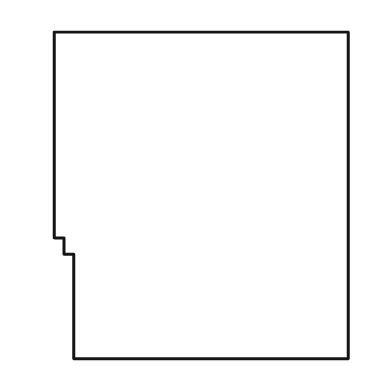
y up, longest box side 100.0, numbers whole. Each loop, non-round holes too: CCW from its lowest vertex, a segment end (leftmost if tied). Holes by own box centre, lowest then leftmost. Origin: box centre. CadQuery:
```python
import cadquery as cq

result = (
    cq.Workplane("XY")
    .moveTo(-39.0, -50.0)
    .lineTo(45.0, -50.0)
    .lineTo(45.0, 50.0)
    .lineTo(-45.0, 50.0)
    .lineTo(-45.0, -13.0)
    .lineTo(-42.0, -13.0)
    .lineTo(-42.0, -18.0)
    .lineTo(-39.0, -18.0)
    .close()
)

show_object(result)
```